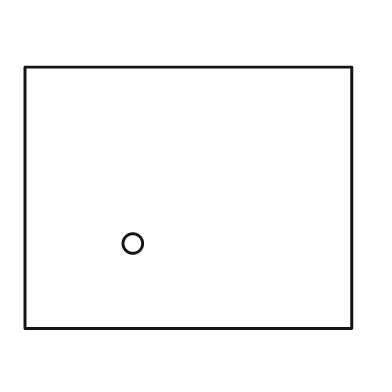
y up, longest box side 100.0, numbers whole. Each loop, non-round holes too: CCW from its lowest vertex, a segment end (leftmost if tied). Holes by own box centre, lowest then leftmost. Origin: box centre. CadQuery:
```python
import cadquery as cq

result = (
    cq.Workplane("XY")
    .moveTo(-50.0, -40.0)
    .lineTo(50.0, -40.0)
    .lineTo(50.0, 40.0)
    .lineTo(-50.0, 40.0)
    .close()
    .moveTo(-17.0, -14.0)
    .circle(3.0)
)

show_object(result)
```